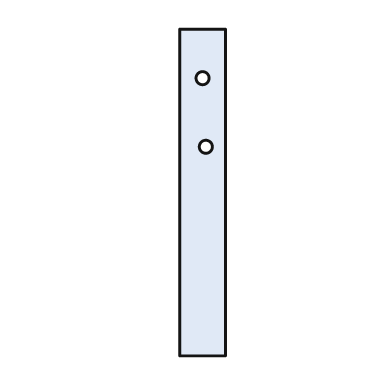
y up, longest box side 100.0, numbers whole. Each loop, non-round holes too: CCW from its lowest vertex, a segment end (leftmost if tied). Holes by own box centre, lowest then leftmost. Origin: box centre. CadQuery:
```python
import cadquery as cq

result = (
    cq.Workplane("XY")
    .moveTo(-7.0, -50.0)
    .lineTo(7.0, -50.0)
    .lineTo(7.0, 50.0)
    .lineTo(-7.0, 50.0)
    .close()
    .moveTo(1.0, 14.0)
    .circle(2.0)
    .moveTo(0.0, 35.0)
    .circle(2.0)
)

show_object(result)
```